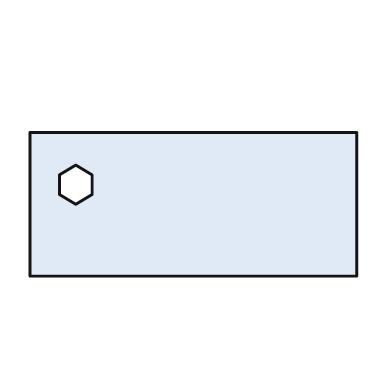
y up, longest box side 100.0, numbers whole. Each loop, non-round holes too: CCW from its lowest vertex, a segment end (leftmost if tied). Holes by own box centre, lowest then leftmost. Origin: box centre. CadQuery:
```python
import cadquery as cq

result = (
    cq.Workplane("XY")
    .moveTo(-50.0, -22.0)
    .lineTo(50.0, -22.0)
    .lineTo(50.0, 22.0)
    .lineTo(-50.0, 22.0)
    .close()
    .moveTo(-36.0, 0.0)
    .lineTo(-31.0, 3.0)
    .lineTo(-31.0, 9.0)
    .lineTo(-36.0, 12.0)
    .lineTo(-41.0, 9.0)
    .lineTo(-41.0, 3.0)
    .close()
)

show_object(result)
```